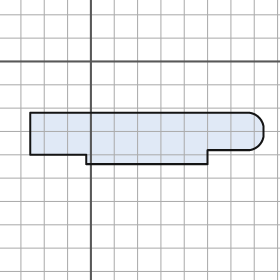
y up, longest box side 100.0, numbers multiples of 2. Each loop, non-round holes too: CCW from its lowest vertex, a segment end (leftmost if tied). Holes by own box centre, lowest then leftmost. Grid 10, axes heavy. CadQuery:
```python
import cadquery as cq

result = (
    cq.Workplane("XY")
    .moveTo(-2.0, -44.0)
    .lineTo(50.0, -44.0)
    .lineTo(50.0, -38.0)
    .lineTo(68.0, -38.0)
    .threePointArc((72.0, -36.0), (74.0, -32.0))
    .lineTo(74.0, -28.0)
    .threePointArc((72.0, -24.0), (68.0, -22.0))
    .lineTo(-26.0, -22.0)
    .lineTo(-26.0, -40.0)
    .lineTo(-2.0, -40.0)
    .close()
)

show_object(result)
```